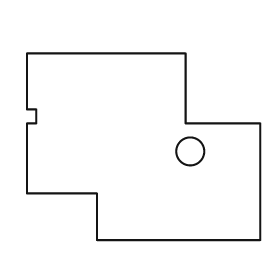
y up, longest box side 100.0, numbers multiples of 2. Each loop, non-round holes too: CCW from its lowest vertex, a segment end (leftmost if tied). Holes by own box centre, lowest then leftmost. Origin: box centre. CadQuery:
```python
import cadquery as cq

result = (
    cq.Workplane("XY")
    .moveTo(-20.0, -40.0)
    .lineTo(50.0, -40.0)
    .lineTo(50.0, 10.0)
    .lineTo(18.0, 10.0)
    .lineTo(18.0, 40.0)
    .lineTo(-50.0, 40.0)
    .lineTo(-50.0, 16.0)
    .lineTo(-46.0, 16.0)
    .lineTo(-46.0, 10.0)
    .lineTo(-50.0, 10.0)
    .lineTo(-50.0, -20.0)
    .lineTo(-20.0, -20.0)
    .close()
    .moveTo(20.0, -2.0)
    .circle(6.0)
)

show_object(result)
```